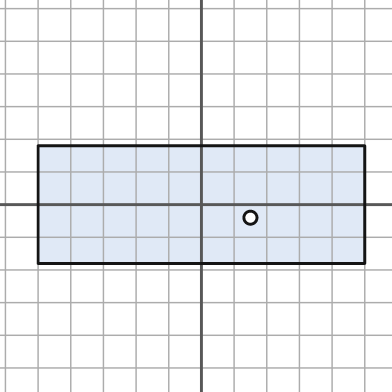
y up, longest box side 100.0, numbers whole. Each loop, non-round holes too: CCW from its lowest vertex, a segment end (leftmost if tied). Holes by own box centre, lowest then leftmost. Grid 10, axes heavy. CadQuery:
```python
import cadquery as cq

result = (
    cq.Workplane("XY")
    .moveTo(-50.0, -18.0)
    .lineTo(50.0, -18.0)
    .lineTo(50.0, 18.0)
    .lineTo(-50.0, 18.0)
    .close()
    .moveTo(15.0, -4.0)
    .circle(2.0)
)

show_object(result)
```